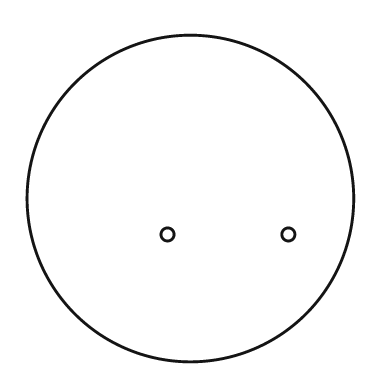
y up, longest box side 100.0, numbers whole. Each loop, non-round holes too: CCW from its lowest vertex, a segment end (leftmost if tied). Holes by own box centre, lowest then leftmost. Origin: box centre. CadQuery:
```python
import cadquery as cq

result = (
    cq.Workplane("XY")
    .moveTo(0.0, 0.0)
    .circle(50.0)
    .moveTo(-7.0, -11.0)
    .circle(2.0)
    .moveTo(30.0, -11.0)
    .circle(2.0)
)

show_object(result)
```